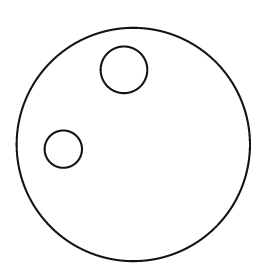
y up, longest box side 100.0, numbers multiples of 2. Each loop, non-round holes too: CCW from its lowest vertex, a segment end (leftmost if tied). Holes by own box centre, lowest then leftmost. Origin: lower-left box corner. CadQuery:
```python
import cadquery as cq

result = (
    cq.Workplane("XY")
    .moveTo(50.0, 50.0)
    .circle(50.0)
    .moveTo(20.0, 48.0)
    .circle(8.0)
    .moveTo(46.0, 82.0)
    .circle(10.0)
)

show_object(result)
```